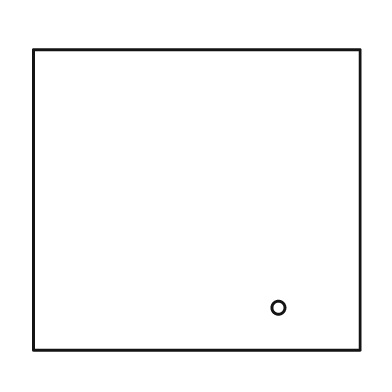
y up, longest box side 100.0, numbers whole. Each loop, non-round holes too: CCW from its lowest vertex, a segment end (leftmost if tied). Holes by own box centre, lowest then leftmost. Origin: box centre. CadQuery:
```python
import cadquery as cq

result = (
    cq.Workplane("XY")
    .moveTo(-50.0, -46.0)
    .lineTo(50.0, -46.0)
    .lineTo(50.0, 46.0)
    .lineTo(-50.0, 46.0)
    .close()
    .moveTo(25.0, -33.0)
    .circle(2.0)
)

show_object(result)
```